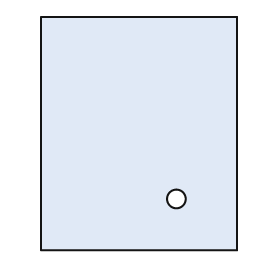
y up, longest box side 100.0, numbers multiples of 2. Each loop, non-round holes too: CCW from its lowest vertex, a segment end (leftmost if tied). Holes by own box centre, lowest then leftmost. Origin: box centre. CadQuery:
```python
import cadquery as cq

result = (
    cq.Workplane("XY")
    .moveTo(-42.0, -50.0)
    .lineTo(42.0, -50.0)
    .lineTo(42.0, 50.0)
    .lineTo(-42.0, 50.0)
    .close()
    .moveTo(16.0, -28.0)
    .circle(4.0)
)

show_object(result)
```